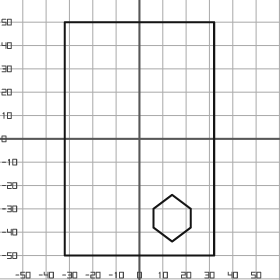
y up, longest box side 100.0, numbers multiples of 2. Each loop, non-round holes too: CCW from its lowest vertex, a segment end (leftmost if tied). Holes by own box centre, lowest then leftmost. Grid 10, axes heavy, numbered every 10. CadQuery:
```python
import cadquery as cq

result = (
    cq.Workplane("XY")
    .moveTo(-32.0, -50.0)
    .lineTo(32.0, -50.0)
    .lineTo(32.0, 50.0)
    .lineTo(-32.0, 50.0)
    .close()
    .moveTo(14.0, -44.0)
    .lineTo(22.0, -38.0)
    .lineTo(22.0, -30.0)
    .lineTo(14.0, -24.0)
    .lineTo(6.0, -30.0)
    .lineTo(6.0, -38.0)
    .close()
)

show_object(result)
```